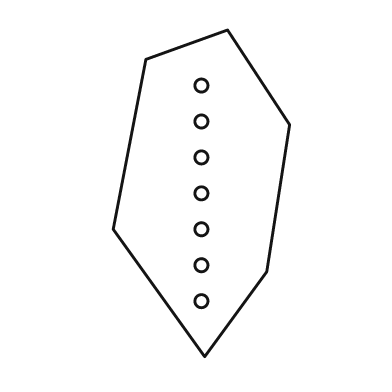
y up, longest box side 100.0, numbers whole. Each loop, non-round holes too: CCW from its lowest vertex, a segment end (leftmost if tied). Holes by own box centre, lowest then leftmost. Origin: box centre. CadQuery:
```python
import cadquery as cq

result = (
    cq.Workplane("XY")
    .moveTo(1.0, -50.0)
    .lineTo(20.0, -24.0)
    .lineTo(27.0, 21.0)
    .lineTo(8.0, 50.0)
    .lineTo(-17.0, 41.0)
    .lineTo(-27.0, -11.0)
    .close()
    .moveTo(0.0, -33.0)
    .circle(2.0)
    .moveTo(0.0, -22.0)
    .circle(2.0)
    .moveTo(0.0, -11.0)
    .circle(2.0)
    .moveTo(0.0, 0.0)
    .circle(2.0)
    .moveTo(0.0, 11.0)
    .circle(2.0)
    .moveTo(0.0, 22.0)
    .circle(2.0)
    .moveTo(0.0, 33.0)
    .circle(2.0)
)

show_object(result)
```